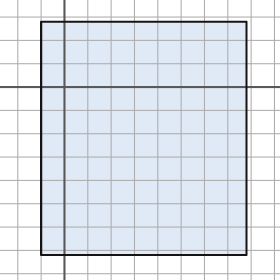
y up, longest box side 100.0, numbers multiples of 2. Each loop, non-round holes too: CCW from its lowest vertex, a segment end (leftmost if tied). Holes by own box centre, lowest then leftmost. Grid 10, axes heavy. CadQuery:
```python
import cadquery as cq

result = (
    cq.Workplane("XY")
    .moveTo(-10.0, -72.0)
    .lineTo(78.0, -72.0)
    .lineTo(78.0, 28.0)
    .lineTo(-10.0, 28.0)
    .close()
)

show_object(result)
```